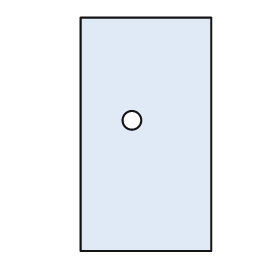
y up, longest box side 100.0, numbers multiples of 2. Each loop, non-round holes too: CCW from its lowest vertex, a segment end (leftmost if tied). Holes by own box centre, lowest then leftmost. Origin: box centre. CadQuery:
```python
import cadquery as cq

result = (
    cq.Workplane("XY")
    .moveTo(-28.0, -50.0)
    .lineTo(28.0, -50.0)
    .lineTo(28.0, 50.0)
    .lineTo(-28.0, 50.0)
    .close()
    .moveTo(-6.0, 6.0)
    .circle(4.0)
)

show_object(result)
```